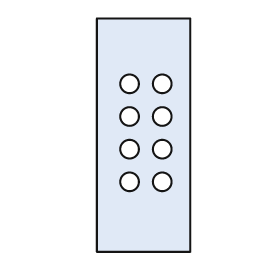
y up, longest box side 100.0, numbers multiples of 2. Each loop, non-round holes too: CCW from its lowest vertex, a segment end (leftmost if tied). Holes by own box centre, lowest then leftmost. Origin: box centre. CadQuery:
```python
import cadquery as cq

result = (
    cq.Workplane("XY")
    .moveTo(-20.0, -50.0)
    .lineTo(20.0, -50.0)
    .lineTo(20.0, 50.0)
    .lineTo(-20.0, 50.0)
    .close()
    .moveTo(-6.0, -20.0)
    .circle(4.0)
    .moveTo(8.0, -20.0)
    .circle(4.0)
    .moveTo(-6.0, -6.0)
    .circle(4.0)
    .moveTo(8.0, -6.0)
    .circle(4.0)
    .moveTo(-6.0, 8.0)
    .circle(4.0)
    .moveTo(8.0, 8.0)
    .circle(4.0)
    .moveTo(-6.0, 22.0)
    .circle(4.0)
    .moveTo(8.0, 22.0)
    .circle(4.0)
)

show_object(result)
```